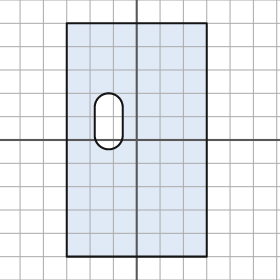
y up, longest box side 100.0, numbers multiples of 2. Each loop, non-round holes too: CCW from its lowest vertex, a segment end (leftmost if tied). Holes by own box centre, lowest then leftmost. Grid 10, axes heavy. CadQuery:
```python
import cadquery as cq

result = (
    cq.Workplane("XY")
    .moveTo(-30.0, -50.0)
    .lineTo(30.0, -50.0)
    .lineTo(30.0, 50.0)
    .lineTo(-30.0, 50.0)
    .close()
    .moveTo(-18.0, 2.0)
    .threePointArc((-12.0, -4.0), (-6.0, 2.0))
    .lineTo(-6.0, 14.0)
    .threePointArc((-12.0, 20.0), (-18.0, 14.0))
    .close()
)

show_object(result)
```